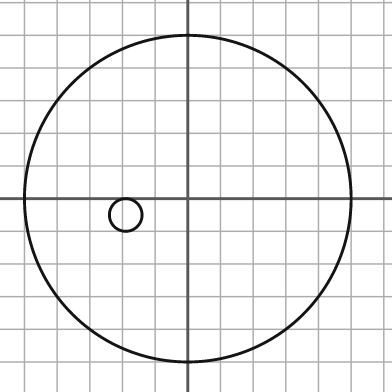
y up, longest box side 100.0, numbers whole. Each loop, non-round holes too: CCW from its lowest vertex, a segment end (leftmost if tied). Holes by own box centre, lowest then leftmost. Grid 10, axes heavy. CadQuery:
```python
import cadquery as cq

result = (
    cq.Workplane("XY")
    .moveTo(0.0, 0.0)
    .circle(50.0)
    .moveTo(-19.0, -5.0)
    .circle(5.0)
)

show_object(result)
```